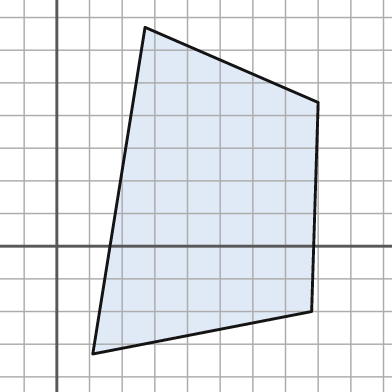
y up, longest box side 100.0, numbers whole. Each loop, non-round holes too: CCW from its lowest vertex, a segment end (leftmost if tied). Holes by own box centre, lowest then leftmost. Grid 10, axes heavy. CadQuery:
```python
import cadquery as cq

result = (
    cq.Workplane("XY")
    .moveTo(11.0, -33.0)
    .lineTo(78.0, -20.0)
    .lineTo(80.0, 44.0)
    .lineTo(27.0, 67.0)
    .close()
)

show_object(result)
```